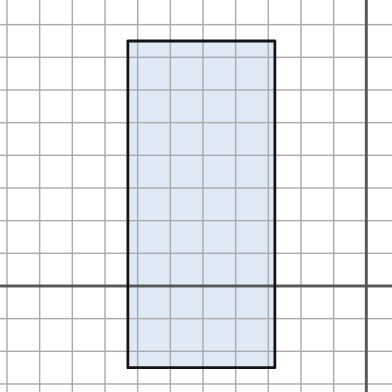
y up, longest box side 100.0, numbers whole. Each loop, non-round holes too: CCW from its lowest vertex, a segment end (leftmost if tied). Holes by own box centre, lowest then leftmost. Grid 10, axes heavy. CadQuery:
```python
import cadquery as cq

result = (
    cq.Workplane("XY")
    .moveTo(-73.0, -25.0)
    .lineTo(-28.0, -25.0)
    .lineTo(-28.0, 75.0)
    .lineTo(-73.0, 75.0)
    .close()
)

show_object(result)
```